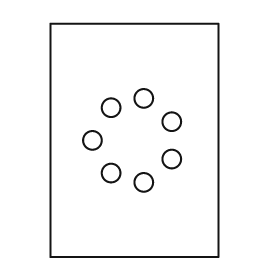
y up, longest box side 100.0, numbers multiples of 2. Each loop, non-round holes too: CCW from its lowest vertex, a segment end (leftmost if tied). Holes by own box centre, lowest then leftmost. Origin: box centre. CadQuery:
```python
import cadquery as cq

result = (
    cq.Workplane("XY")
    .moveTo(-36.0, -50.0)
    .lineTo(36.0, -50.0)
    .lineTo(36.0, 50.0)
    .lineTo(-36.0, 50.0)
    .close()
    .moveTo(4.0, -18.0)
    .circle(4.0)
    .moveTo(-10.0, -14.0)
    .circle(4.0)
    .moveTo(16.0, -8.0)
    .circle(4.0)
    .moveTo(-18.0, 0.0)
    .circle(4.0)
    .moveTo(16.0, 8.0)
    .circle(4.0)
    .moveTo(-10.0, 14.0)
    .circle(4.0)
    .moveTo(4.0, 18.0)
    .circle(4.0)
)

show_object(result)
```